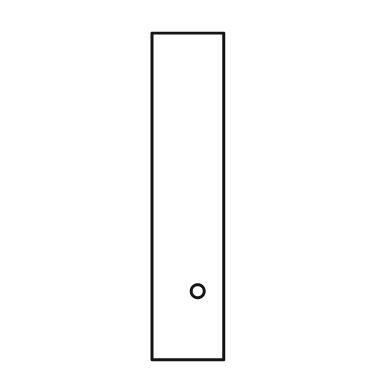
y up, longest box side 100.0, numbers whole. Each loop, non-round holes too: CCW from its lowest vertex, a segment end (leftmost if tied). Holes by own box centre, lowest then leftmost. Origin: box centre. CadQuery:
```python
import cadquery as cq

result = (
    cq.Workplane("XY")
    .moveTo(-11.0, -50.0)
    .lineTo(11.0, -50.0)
    .lineTo(11.0, 50.0)
    .lineTo(-11.0, 50.0)
    .close()
    .moveTo(3.0, -29.0)
    .circle(2.0)
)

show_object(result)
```